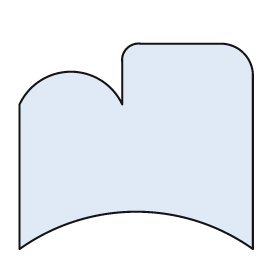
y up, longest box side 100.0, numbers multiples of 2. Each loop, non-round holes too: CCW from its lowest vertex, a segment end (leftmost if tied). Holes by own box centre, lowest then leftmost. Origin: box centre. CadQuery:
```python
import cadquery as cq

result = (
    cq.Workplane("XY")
    .moveTo(-50.0, -44.0)
    .threePointArc((0.0, -28.0), (50.0, -44.0))
    .lineTo(50.0, 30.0)
    .threePointArc((46.0, 40.0), (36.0, 44.0))
    .lineTo(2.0, 44.0)
    .threePointArc((-4.0, 42.0), (-6.0, 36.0))
    .lineTo(-6.0, 18.0)
    .threePointArc((-28.0, 32.0), (-50.0, 18.0))
    .close()
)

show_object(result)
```